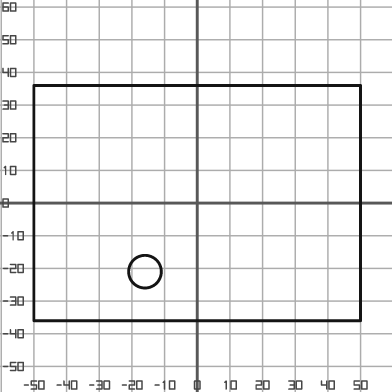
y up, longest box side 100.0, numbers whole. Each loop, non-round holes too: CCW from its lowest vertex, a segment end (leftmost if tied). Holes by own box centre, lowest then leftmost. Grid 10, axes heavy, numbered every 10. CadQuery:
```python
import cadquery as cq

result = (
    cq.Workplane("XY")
    .moveTo(-50.0, -36.0)
    .lineTo(50.0, -36.0)
    .lineTo(50.0, 36.0)
    .lineTo(-50.0, 36.0)
    .close()
    .moveTo(-16.0, -21.0)
    .circle(5.0)
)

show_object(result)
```